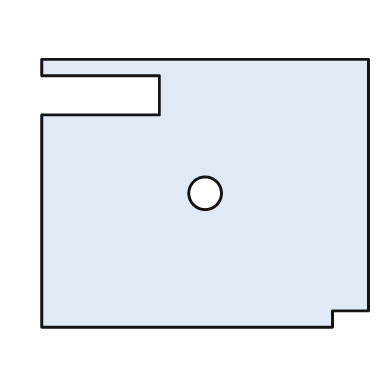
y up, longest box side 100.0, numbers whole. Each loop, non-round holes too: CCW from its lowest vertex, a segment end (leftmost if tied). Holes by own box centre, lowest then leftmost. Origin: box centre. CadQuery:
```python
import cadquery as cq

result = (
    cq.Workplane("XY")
    .moveTo(-50.0, -41.0)
    .lineTo(39.0, -41.0)
    .lineTo(39.0, -36.0)
    .lineTo(50.0, -36.0)
    .lineTo(50.0, 41.0)
    .lineTo(-50.0, 41.0)
    .lineTo(-50.0, 36.0)
    .lineTo(-14.0, 36.0)
    .lineTo(-14.0, 24.0)
    .lineTo(-50.0, 24.0)
    .close()
    .moveTo(0.0, 0.0)
    .circle(5.0)
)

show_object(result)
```